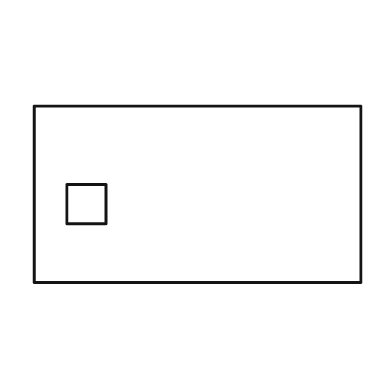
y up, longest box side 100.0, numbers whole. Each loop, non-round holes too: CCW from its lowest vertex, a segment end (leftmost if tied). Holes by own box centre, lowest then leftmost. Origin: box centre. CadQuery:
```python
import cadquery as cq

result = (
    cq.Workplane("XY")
    .moveTo(-50.0, -27.0)
    .lineTo(50.0, -27.0)
    .lineTo(50.0, 27.0)
    .lineTo(-50.0, 27.0)
    .close()
    .moveTo(-40.0, -9.0)
    .lineTo(-28.0, -9.0)
    .lineTo(-28.0, 3.0)
    .lineTo(-40.0, 3.0)
    .close()
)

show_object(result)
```